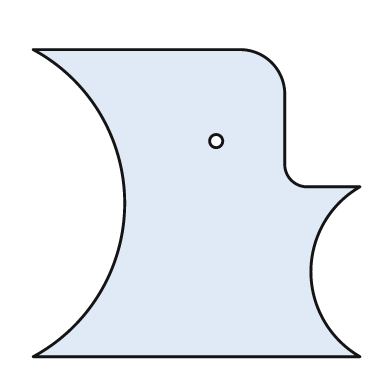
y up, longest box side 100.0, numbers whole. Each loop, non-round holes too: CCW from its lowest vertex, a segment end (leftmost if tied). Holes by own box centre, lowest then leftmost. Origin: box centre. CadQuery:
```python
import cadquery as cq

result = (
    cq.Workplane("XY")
    .moveTo(-50.0, -47.0)
    .lineTo(50.0, -47.0)
    .threePointArc((35.0, -21.0), (50.0, 5.0))
    .lineTo(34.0, 5.0)
    .threePointArc((29.0, 7.0), (27.0, 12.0))
    .lineTo(27.0, 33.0)
    .threePointArc((23.0, 43.0), (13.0, 47.0))
    .lineTo(-50.0, 47.0)
    .threePointArc((-22.0, 0.0), (-50.0, -47.0))
    .close()
    .moveTo(6.0, 19.0)
    .circle(2.0)
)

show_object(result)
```